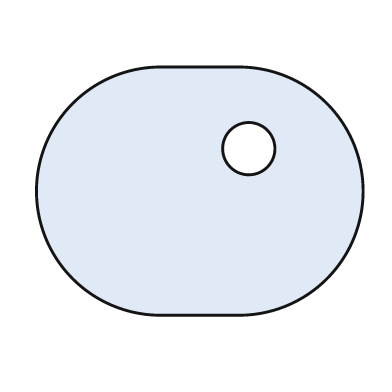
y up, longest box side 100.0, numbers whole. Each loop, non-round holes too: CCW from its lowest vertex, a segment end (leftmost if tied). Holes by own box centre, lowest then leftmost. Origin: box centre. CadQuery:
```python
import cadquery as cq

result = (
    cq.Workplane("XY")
    .moveTo(-12.0, -38.0)
    .lineTo(12.0, -38.0)
    .threePointArc((50.0, 0.0), (12.0, 38.0))
    .lineTo(-12.0, 38.0)
    .threePointArc((-50.0, 0.0), (-12.0, -38.0))
    .close()
    .moveTo(15.0, 13.0)
    .circle(8.0)
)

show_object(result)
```